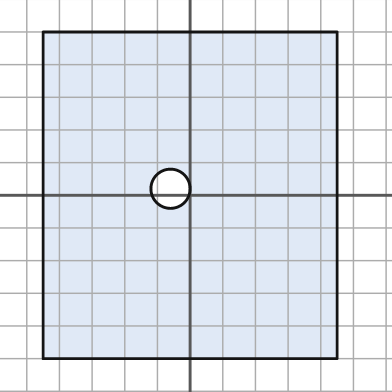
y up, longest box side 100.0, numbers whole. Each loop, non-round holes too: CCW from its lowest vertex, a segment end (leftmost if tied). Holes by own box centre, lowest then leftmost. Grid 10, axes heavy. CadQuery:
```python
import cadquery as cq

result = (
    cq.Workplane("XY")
    .moveTo(-45.0, -50.0)
    .lineTo(45.0, -50.0)
    .lineTo(45.0, 50.0)
    .lineTo(-45.0, 50.0)
    .close()
    .moveTo(-6.0, 2.0)
    .circle(6.0)
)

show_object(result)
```